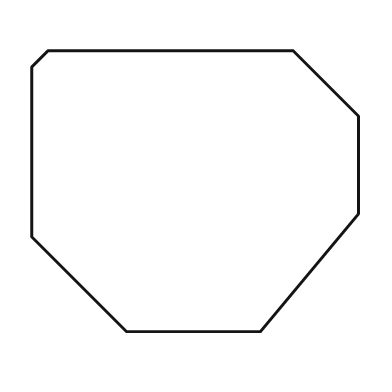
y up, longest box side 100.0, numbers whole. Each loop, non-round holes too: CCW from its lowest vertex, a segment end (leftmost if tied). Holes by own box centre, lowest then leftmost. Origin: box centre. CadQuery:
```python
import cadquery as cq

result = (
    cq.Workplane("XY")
    .moveTo(-21.0, -43.0)
    .lineTo(20.0, -43.0)
    .lineTo(50.0, -7.0)
    .lineTo(50.0, 23.0)
    .lineTo(30.0, 43.0)
    .lineTo(-45.0, 43.0)
    .lineTo(-50.0, 38.0)
    .lineTo(-50.0, -14.0)
    .close()
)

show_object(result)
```